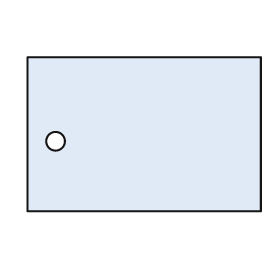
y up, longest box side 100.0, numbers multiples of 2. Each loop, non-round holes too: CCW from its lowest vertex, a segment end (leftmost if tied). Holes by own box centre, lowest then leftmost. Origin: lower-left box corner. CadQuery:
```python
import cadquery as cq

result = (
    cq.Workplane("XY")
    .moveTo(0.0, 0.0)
    .lineTo(100.0, 0.0)
    .lineTo(100.0, 66.0)
    .lineTo(0.0, 66.0)
    .close()
    .moveTo(12.0, 30.0)
    .circle(4.0)
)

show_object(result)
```